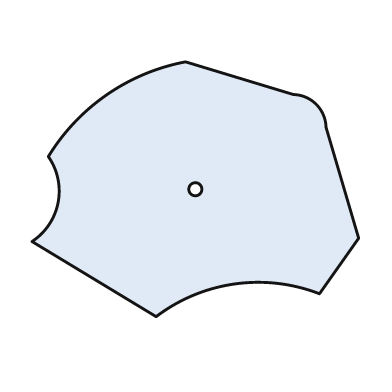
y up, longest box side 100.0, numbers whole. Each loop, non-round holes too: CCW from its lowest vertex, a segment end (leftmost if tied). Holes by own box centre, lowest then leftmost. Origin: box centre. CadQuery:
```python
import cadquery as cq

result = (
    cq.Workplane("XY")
    .moveTo(-12.0, -39.0)
    .threePointArc((12.0, -29.0), (38.0, -32.0))
    .lineTo(50.0, -15.0)
    .lineTo(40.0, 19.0)
    .threePointArc((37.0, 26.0), (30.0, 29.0))
    .lineTo(-3.0, 39.0)
    .threePointArc((-27.0, 29.0), (-45.0, 10.0))
    .threePointArc((-42.0, -4.0), (-50.0, -16.0))
    .close()
    .moveTo(0.0, 0.0)
    .circle(2.0)
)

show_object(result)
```